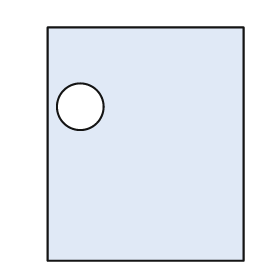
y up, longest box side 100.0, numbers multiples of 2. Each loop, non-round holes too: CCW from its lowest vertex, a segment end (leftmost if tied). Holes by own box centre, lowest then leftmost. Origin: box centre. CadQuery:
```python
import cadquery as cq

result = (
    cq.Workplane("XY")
    .moveTo(-42.0, -50.0)
    .lineTo(42.0, -50.0)
    .lineTo(42.0, 50.0)
    .lineTo(-42.0, 50.0)
    .close()
    .moveTo(-28.0, 16.0)
    .circle(10.0)
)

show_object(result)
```